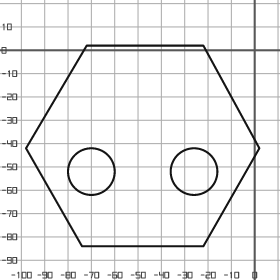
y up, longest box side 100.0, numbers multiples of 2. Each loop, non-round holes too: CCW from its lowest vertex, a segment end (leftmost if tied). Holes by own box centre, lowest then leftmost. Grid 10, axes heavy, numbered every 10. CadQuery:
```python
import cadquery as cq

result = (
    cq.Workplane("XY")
    .moveTo(-74.0, -84.0)
    .lineTo(-22.0, -84.0)
    .lineTo(2.0, -42.0)
    .lineTo(-22.0, 2.0)
    .lineTo(-72.0, 2.0)
    .lineTo(-98.0, -42.0)
    .close()
    .moveTo(-70.0, -52.0)
    .circle(10.0)
    .moveTo(-26.0, -52.0)
    .circle(10.0)
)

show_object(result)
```